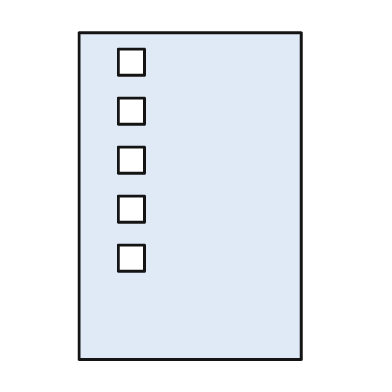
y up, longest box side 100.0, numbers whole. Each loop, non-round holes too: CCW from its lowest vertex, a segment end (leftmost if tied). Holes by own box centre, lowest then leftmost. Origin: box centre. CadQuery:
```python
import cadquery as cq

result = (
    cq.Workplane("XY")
    .moveTo(-34.0, -50.0)
    .lineTo(34.0, -50.0)
    .lineTo(34.0, 50.0)
    .lineTo(-34.0, 50.0)
    .close()
    .moveTo(-22.0, -23.0)
    .lineTo(-14.0, -23.0)
    .lineTo(-14.0, -15.0)
    .lineTo(-22.0, -15.0)
    .close()
    .moveTo(-22.0, -8.0)
    .lineTo(-14.0, -8.0)
    .lineTo(-14.0, 0.0)
    .lineTo(-22.0, 0.0)
    .close()
    .moveTo(-22.0, 7.0)
    .lineTo(-14.0, 7.0)
    .lineTo(-14.0, 15.0)
    .lineTo(-22.0, 15.0)
    .close()
    .moveTo(-22.0, 22.0)
    .lineTo(-14.0, 22.0)
    .lineTo(-14.0, 30.0)
    .lineTo(-22.0, 30.0)
    .close()
    .moveTo(-22.0, 37.0)
    .lineTo(-14.0, 37.0)
    .lineTo(-14.0, 45.0)
    .lineTo(-22.0, 45.0)
    .close()
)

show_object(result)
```